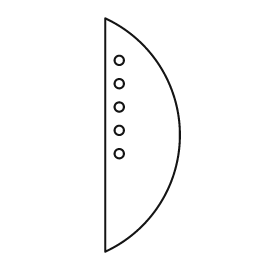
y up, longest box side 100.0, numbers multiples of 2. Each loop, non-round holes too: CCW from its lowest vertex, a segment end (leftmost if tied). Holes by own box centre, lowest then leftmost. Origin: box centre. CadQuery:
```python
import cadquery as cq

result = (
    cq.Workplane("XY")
    .moveTo(-16.0, -50.0)
    .threePointArc((16.0, 0.0), (-16.0, 50.0))
    .close()
    .moveTo(-10.0, -8.0)
    .circle(2.0)
    .moveTo(-10.0, 2.0)
    .circle(2.0)
    .moveTo(-10.0, 12.0)
    .circle(2.0)
    .moveTo(-10.0, 22.0)
    .circle(2.0)
    .moveTo(-10.0, 32.0)
    .circle(2.0)
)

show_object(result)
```